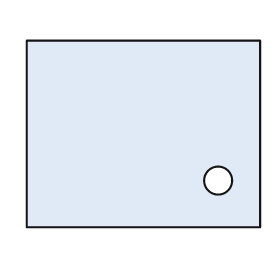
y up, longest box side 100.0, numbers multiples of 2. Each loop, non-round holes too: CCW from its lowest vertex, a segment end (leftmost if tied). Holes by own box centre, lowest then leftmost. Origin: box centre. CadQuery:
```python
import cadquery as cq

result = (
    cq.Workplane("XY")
    .moveTo(-50.0, -40.0)
    .lineTo(50.0, -40.0)
    .lineTo(50.0, 40.0)
    .lineTo(-50.0, 40.0)
    .close()
    .moveTo(32.0, -20.0)
    .circle(6.0)
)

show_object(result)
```